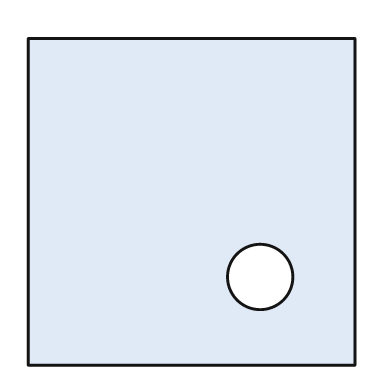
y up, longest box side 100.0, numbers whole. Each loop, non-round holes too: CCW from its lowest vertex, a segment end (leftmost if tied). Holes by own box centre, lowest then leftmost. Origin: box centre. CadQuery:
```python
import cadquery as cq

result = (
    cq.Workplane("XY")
    .moveTo(-50.0, -50.0)
    .lineTo(50.0, -50.0)
    .lineTo(50.0, 50.0)
    .lineTo(-50.0, 50.0)
    .close()
    .moveTo(21.0, -23.0)
    .circle(10.0)
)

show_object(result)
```